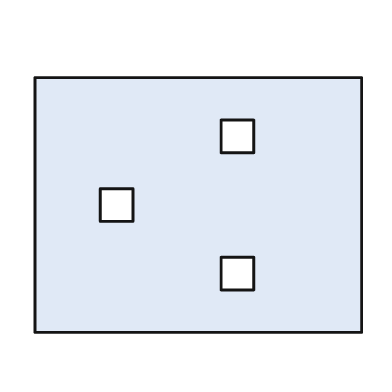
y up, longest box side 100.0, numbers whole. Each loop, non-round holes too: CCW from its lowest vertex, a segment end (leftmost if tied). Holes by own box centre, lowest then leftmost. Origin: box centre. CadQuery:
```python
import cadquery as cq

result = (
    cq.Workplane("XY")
    .moveTo(-50.0, -39.0)
    .lineTo(50.0, -39.0)
    .lineTo(50.0, 39.0)
    .lineTo(-50.0, 39.0)
    .close()
    .moveTo(7.0, -26.0)
    .lineTo(17.0, -26.0)
    .lineTo(17.0, -16.0)
    .lineTo(7.0, -16.0)
    .close()
    .moveTo(-30.0, -5.0)
    .lineTo(-20.0, -5.0)
    .lineTo(-20.0, 5.0)
    .lineTo(-30.0, 5.0)
    .close()
    .moveTo(7.0, 16.0)
    .lineTo(17.0, 16.0)
    .lineTo(17.0, 26.0)
    .lineTo(7.0, 26.0)
    .close()
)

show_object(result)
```